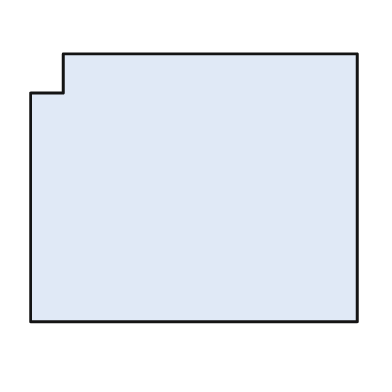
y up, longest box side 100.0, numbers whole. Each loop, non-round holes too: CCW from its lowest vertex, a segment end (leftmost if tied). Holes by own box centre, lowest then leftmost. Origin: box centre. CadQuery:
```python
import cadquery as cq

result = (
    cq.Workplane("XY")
    .moveTo(-50.0, -41.0)
    .lineTo(50.0, -41.0)
    .lineTo(50.0, 41.0)
    .lineTo(-40.0, 41.0)
    .lineTo(-40.0, 29.0)
    .lineTo(-50.0, 29.0)
    .close()
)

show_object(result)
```